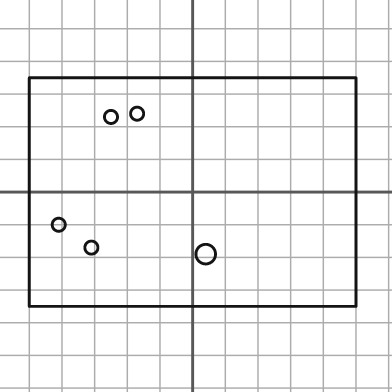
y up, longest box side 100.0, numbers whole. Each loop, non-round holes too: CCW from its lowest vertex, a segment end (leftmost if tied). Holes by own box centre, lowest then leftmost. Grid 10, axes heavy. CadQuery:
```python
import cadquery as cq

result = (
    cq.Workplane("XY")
    .moveTo(-50.0, -35.0)
    .lineTo(50.0, -35.0)
    .lineTo(50.0, 35.0)
    .lineTo(-50.0, 35.0)
    .close()
    .moveTo(4.0, -19.0)
    .circle(3.0)
    .moveTo(-31.0, -17.0)
    .circle(2.0)
    .moveTo(-41.0, -10.0)
    .circle(2.0)
    .moveTo(-25.0, 23.0)
    .circle(2.0)
    .moveTo(-17.0, 24.0)
    .circle(2.0)
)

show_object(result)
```